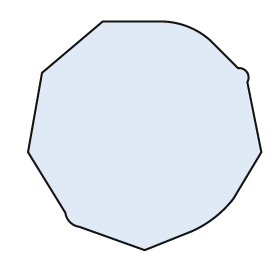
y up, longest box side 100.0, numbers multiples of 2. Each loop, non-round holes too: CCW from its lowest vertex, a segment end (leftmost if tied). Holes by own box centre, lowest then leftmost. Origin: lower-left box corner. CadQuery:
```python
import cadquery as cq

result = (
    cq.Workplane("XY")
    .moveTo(50.0, 0.0)
    .lineTo(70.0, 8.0)
    .threePointArc((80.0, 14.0), (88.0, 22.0))
    .lineTo(100.0, 42.0)
    .lineTo(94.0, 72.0)
    .threePointArc((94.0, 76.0), (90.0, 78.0))
    .lineTo(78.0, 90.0)
    .threePointArc((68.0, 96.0), (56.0, 98.0))
    .lineTo(32.0, 98.0)
    .lineTo(6.0, 76.0)
    .lineTo(0.0, 42.0)
    .lineTo(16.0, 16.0)
    .threePointArc((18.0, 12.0), (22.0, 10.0))
    .close()
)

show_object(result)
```